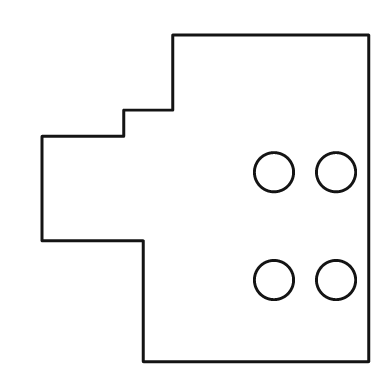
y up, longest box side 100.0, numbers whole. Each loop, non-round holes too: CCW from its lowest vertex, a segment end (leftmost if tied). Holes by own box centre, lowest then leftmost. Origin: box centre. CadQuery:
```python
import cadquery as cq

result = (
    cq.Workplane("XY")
    .moveTo(-19.0, -50.0)
    .lineTo(50.0, -50.0)
    .lineTo(50.0, 50.0)
    .lineTo(-10.0, 50.0)
    .lineTo(-10.0, 27.0)
    .lineTo(-25.0, 27.0)
    .lineTo(-25.0, 19.0)
    .lineTo(-50.0, 19.0)
    .lineTo(-50.0, -13.0)
    .lineTo(-19.0, -13.0)
    .close()
    .moveTo(21.0, -25.0)
    .circle(6.0)
    .moveTo(40.0, -25.0)
    .circle(6.0)
    .moveTo(21.0, 8.0)
    .circle(6.0)
    .moveTo(40.0, 8.0)
    .circle(6.0)
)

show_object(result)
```